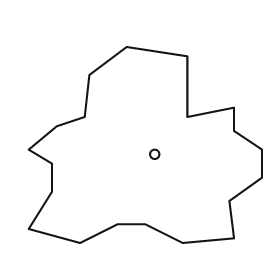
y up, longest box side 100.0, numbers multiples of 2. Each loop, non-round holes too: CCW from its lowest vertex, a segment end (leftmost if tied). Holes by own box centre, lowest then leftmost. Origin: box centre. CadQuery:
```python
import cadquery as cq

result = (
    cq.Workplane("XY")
    .moveTo(-28.0, -42.0)
    .lineTo(-12.0, -34.0)
    .lineTo(0.0, -34.0)
    .lineTo(16.0, -42.0)
    .lineTo(38.0, -40.0)
    .lineTo(36.0, -24.0)
    .lineTo(50.0, -14.0)
    .lineTo(50.0, -2.0)
    .lineTo(38.0, 6.0)
    .lineTo(38.0, 16.0)
    .lineTo(18.0, 12.0)
    .lineTo(18.0, 38.0)
    .lineTo(-8.0, 42.0)
    .lineTo(-24.0, 30.0)
    .lineTo(-26.0, 12.0)
    .lineTo(-38.0, 8.0)
    .lineTo(-50.0, -2.0)
    .lineTo(-40.0, -8.0)
    .lineTo(-40.0, -20.0)
    .lineTo(-50.0, -36.0)
    .close()
    .moveTo(4.0, -4.0)
    .circle(2.0)
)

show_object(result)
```